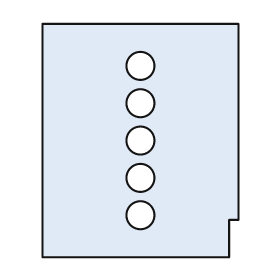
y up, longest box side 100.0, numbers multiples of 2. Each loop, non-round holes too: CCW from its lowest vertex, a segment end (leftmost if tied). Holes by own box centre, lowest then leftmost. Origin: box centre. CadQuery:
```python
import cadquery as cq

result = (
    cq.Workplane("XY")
    .moveTo(-42.0, -50.0)
    .lineTo(38.0, -50.0)
    .lineTo(38.0, -34.0)
    .lineTo(42.0, -34.0)
    .lineTo(42.0, 50.0)
    .lineTo(-42.0, 50.0)
    .close()
    .moveTo(0.0, -32.0)
    .circle(6.0)
    .moveTo(0.0, -16.0)
    .circle(6.0)
    .moveTo(0.0, 0.0)
    .circle(6.0)
    .moveTo(0.0, 16.0)
    .circle(6.0)
    .moveTo(0.0, 32.0)
    .circle(6.0)
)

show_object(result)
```